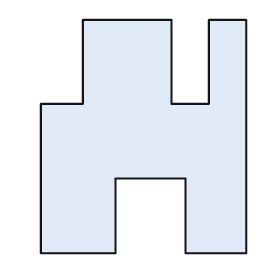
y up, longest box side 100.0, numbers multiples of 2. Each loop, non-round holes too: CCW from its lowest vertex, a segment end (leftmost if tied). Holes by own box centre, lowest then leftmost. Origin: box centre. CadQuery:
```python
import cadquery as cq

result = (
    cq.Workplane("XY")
    .moveTo(-44.0, -50.0)
    .lineTo(-12.0, -50.0)
    .lineTo(-12.0, -18.0)
    .lineTo(18.0, -18.0)
    .lineTo(18.0, -50.0)
    .lineTo(44.0, -50.0)
    .lineTo(44.0, 50.0)
    .lineTo(28.0, 50.0)
    .lineTo(28.0, 14.0)
    .lineTo(12.0, 14.0)
    .lineTo(12.0, 50.0)
    .lineTo(-26.0, 50.0)
    .lineTo(-26.0, 14.0)
    .lineTo(-44.0, 14.0)
    .close()
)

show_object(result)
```